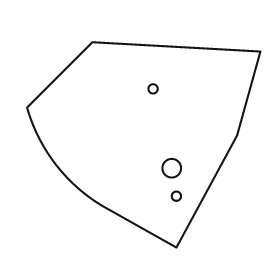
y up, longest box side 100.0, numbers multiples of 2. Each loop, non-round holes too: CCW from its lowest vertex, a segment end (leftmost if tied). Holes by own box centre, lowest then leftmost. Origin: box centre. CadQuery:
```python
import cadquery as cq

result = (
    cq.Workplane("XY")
    .moveTo(14.0, -44.0)
    .lineTo(40.0, 4.0)
    .lineTo(50.0, 40.0)
    .lineTo(-22.0, 44.0)
    .lineTo(-50.0, 16.0)
    .threePointArc((-38.0, -8.0), (-18.0, -26.0))
    .close()
    .moveTo(14.0, -22.0)
    .circle(2.0)
    .moveTo(12.0, -10.0)
    .circle(4.0)
    .moveTo(4.0, 24.0)
    .circle(2.0)
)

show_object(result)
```